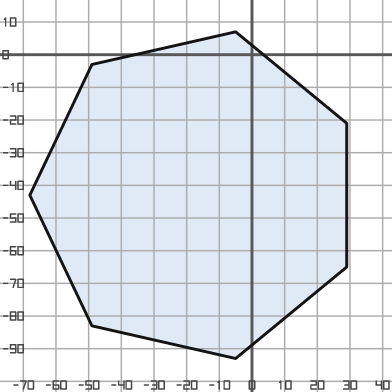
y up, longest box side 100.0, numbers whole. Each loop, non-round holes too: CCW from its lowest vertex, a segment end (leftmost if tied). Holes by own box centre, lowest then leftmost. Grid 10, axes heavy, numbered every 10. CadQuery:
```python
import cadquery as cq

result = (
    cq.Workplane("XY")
    .moveTo(-5.0, -93.0)
    .lineTo(29.0, -65.0)
    .lineTo(29.0, -21.0)
    .lineTo(-5.0, 7.0)
    .lineTo(-49.0, -3.0)
    .lineTo(-68.0, -43.0)
    .lineTo(-49.0, -83.0)
    .close()
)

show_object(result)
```